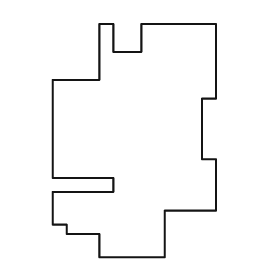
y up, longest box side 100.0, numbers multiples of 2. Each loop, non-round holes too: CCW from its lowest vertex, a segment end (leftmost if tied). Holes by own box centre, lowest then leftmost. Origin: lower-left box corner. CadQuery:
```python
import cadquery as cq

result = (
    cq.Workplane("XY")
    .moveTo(20.0, 0.0)
    .lineTo(48.0, 0.0)
    .lineTo(48.0, 20.0)
    .lineTo(70.0, 20.0)
    .lineTo(70.0, 42.0)
    .lineTo(64.0, 42.0)
    .lineTo(64.0, 68.0)
    .lineTo(70.0, 68.0)
    .lineTo(70.0, 100.0)
    .lineTo(38.0, 100.0)
    .lineTo(38.0, 88.0)
    .lineTo(26.0, 88.0)
    .lineTo(26.0, 100.0)
    .lineTo(20.0, 100.0)
    .lineTo(20.0, 76.0)
    .lineTo(0.0, 76.0)
    .lineTo(0.0, 34.0)
    .lineTo(26.0, 34.0)
    .lineTo(26.0, 28.0)
    .lineTo(0.0, 28.0)
    .lineTo(0.0, 14.0)
    .lineTo(6.0, 14.0)
    .lineTo(6.0, 10.0)
    .lineTo(20.0, 10.0)
    .close()
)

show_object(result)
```